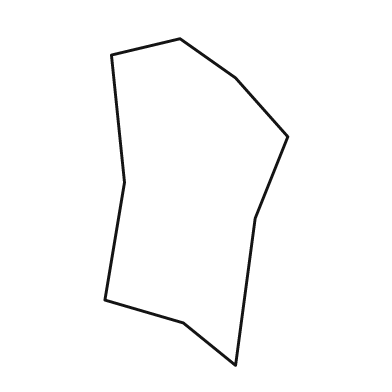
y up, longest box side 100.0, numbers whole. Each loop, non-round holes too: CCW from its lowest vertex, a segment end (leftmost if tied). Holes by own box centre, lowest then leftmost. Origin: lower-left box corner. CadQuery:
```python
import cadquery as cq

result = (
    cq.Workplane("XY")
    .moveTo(40.0, 0.0)
    .lineTo(46.0, 45.0)
    .lineTo(56.0, 70.0)
    .lineTo(40.0, 88.0)
    .lineTo(23.0, 100.0)
    .lineTo(2.0, 95.0)
    .lineTo(6.0, 56.0)
    .lineTo(0.0, 20.0)
    .lineTo(24.0, 13.0)
    .close()
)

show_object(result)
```